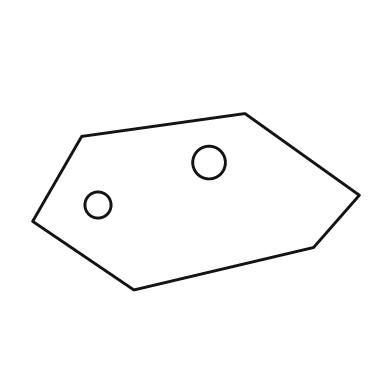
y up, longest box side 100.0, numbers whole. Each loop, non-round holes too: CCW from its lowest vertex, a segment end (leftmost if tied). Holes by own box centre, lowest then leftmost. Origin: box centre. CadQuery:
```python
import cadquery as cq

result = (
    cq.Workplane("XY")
    .moveTo(-19.0, -27.0)
    .lineTo(36.0, -14.0)
    .lineTo(50.0, 2.0)
    .lineTo(15.0, 27.0)
    .lineTo(-35.0, 20.0)
    .lineTo(-50.0, -6.0)
    .close()
    .moveTo(-30.0, -1.0)
    .circle(4.0)
    .moveTo(4.0, 12.0)
    .circle(5.0)
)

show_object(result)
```